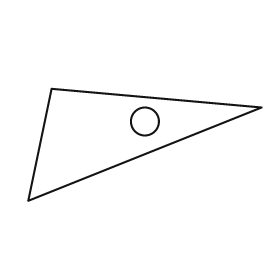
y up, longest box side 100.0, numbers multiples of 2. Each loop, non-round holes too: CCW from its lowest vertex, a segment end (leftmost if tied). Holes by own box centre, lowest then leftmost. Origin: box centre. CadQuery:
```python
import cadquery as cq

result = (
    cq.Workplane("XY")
    .moveTo(-50.0, -24.0)
    .lineTo(50.0, 16.0)
    .lineTo(-40.0, 24.0)
    .close()
    .moveTo(0.0, 10.0)
    .circle(6.0)
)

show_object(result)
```